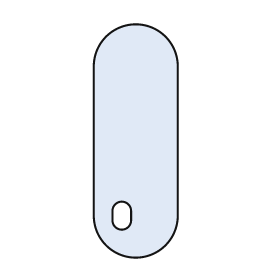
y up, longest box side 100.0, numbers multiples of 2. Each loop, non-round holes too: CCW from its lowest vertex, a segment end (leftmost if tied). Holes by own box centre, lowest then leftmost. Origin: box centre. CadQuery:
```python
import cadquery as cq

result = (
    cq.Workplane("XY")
    .moveTo(-18.0, -32.0)
    .threePointArc((0.0, -50.0), (18.0, -32.0))
    .lineTo(18.0, 32.0)
    .threePointArc((0.0, 50.0), (-18.0, 32.0))
    .close()
    .moveTo(-10.0, -34.0)
    .threePointArc((-6.0, -38.0), (-2.0, -34.0))
    .lineTo(-2.0, -30.0)
    .threePointArc((-6.0, -26.0), (-10.0, -30.0))
    .close()
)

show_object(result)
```